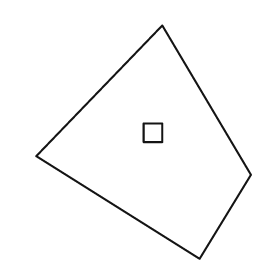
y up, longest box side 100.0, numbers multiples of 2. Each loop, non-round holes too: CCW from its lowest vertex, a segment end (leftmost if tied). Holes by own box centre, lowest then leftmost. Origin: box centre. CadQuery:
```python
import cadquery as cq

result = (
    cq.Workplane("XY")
    .moveTo(24.0, -50.0)
    .lineTo(46.0, -14.0)
    .lineTo(8.0, 50.0)
    .lineTo(-46.0, -6.0)
    .close()
    .moveTo(0.0, 0.0)
    .lineTo(8.0, 0.0)
    .lineTo(8.0, 8.0)
    .lineTo(0.0, 8.0)
    .close()
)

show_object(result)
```